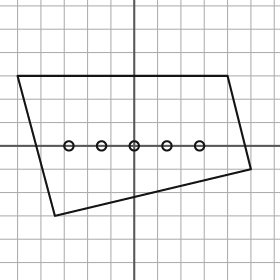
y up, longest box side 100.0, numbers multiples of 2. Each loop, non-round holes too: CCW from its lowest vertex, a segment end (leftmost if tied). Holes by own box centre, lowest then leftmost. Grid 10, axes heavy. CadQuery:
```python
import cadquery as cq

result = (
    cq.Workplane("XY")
    .moveTo(-34.0, -30.0)
    .lineTo(50.0, -10.0)
    .lineTo(40.0, 30.0)
    .lineTo(-50.0, 30.0)
    .close()
    .moveTo(-28.0, 0.0)
    .circle(2.0)
    .moveTo(-14.0, 0.0)
    .circle(2.0)
    .moveTo(0.0, 0.0)
    .circle(2.0)
    .moveTo(14.0, 0.0)
    .circle(2.0)
    .moveTo(28.0, 0.0)
    .circle(2.0)
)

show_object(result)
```